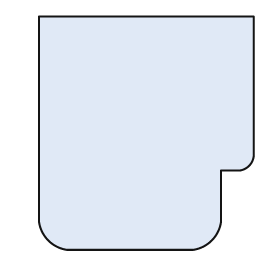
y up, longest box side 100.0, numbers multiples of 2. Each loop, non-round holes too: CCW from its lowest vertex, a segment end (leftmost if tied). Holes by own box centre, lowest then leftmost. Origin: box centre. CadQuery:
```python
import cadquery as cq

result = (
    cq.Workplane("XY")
    .moveTo(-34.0, -50.0)
    .lineTo(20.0, -50.0)
    .threePointArc((28.0, -46.0), (32.0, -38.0))
    .lineTo(32.0, -16.0)
    .lineTo(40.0, -16.0)
    .threePointArc((44.0, -14.0), (46.0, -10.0))
    .lineTo(46.0, 50.0)
    .lineTo(-46.0, 50.0)
    .lineTo(-46.0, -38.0)
    .threePointArc((-42.0, -46.0), (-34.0, -50.0))
    .close()
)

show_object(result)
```